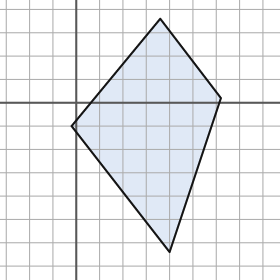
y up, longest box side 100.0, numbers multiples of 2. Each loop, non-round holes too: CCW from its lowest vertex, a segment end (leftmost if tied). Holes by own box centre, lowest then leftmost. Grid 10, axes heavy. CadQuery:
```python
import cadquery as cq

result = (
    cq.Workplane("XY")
    .moveTo(40.0, -64.0)
    .lineTo(62.0, 2.0)
    .lineTo(36.0, 36.0)
    .lineTo(-2.0, -10.0)
    .close()
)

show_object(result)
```